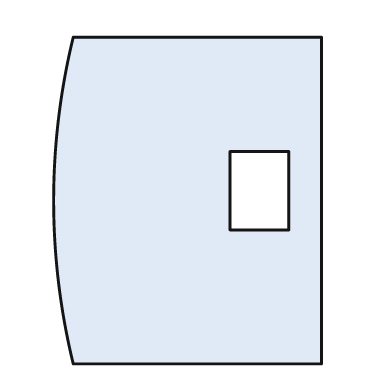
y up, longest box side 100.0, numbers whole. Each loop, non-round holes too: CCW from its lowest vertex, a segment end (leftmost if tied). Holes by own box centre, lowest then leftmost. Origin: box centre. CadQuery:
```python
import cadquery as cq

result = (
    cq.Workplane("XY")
    .moveTo(-35.0, -50.0)
    .lineTo(41.0, -50.0)
    .lineTo(41.0, 50.0)
    .lineTo(-35.0, 50.0)
    .threePointArc((-41.0, 0.0), (-35.0, -50.0))
    .close()
    .moveTo(13.0, -9.0)
    .lineTo(31.0, -9.0)
    .lineTo(31.0, 15.0)
    .lineTo(13.0, 15.0)
    .close()
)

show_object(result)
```